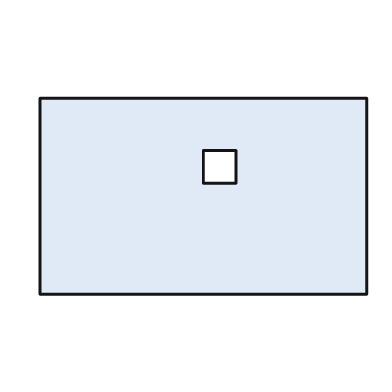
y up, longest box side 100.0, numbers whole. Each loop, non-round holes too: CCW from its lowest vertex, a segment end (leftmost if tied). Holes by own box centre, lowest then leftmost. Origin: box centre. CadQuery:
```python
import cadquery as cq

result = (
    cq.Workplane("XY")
    .moveTo(-50.0, -30.0)
    .lineTo(50.0, -30.0)
    .lineTo(50.0, 30.0)
    .lineTo(-50.0, 30.0)
    .close()
    .moveTo(0.0, 4.0)
    .lineTo(10.0, 4.0)
    .lineTo(10.0, 14.0)
    .lineTo(0.0, 14.0)
    .close()
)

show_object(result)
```